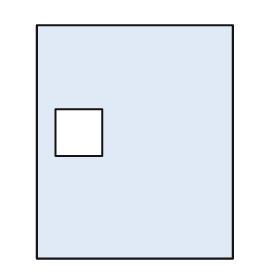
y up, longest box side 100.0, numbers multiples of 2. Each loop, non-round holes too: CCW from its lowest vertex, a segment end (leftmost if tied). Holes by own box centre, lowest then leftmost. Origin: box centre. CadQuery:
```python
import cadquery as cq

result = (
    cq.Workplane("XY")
    .moveTo(-42.0, -50.0)
    .lineTo(42.0, -50.0)
    .lineTo(42.0, 50.0)
    .lineTo(-42.0, 50.0)
    .close()
    .moveTo(-34.0, -6.0)
    .lineTo(-14.0, -6.0)
    .lineTo(-14.0, 14.0)
    .lineTo(-34.0, 14.0)
    .close()
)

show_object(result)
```